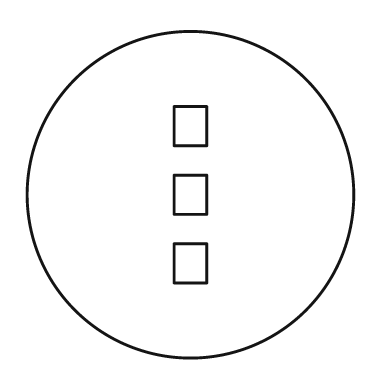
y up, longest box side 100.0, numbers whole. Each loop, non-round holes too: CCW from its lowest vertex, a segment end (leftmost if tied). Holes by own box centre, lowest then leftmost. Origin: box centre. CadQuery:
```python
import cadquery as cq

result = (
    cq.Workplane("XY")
    .moveTo(0.0, 0.0)
    .circle(50.0)
    .moveTo(-5.0, -27.0)
    .lineTo(5.0, -27.0)
    .lineTo(5.0, -15.0)
    .lineTo(-5.0, -15.0)
    .close()
    .moveTo(-5.0, -6.0)
    .lineTo(5.0, -6.0)
    .lineTo(5.0, 6.0)
    .lineTo(-5.0, 6.0)
    .close()
    .moveTo(-5.0, 15.0)
    .lineTo(5.0, 15.0)
    .lineTo(5.0, 27.0)
    .lineTo(-5.0, 27.0)
    .close()
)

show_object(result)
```